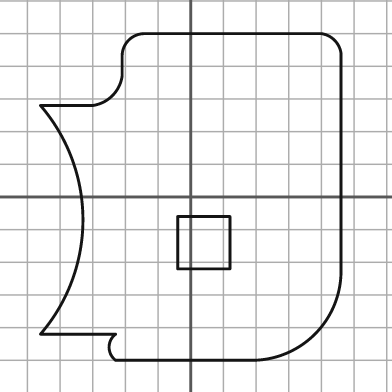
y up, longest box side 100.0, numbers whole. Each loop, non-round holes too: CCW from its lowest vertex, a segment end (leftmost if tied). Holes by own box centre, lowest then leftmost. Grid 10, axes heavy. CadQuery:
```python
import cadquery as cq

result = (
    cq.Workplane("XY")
    .moveTo(-23.0, -50.0)
    .lineTo(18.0, -50.0)
    .threePointArc((38.0, -42.0), (46.0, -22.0))
    .lineTo(46.0, 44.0)
    .threePointArc((44.0, 48.0), (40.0, 50.0))
    .lineTo(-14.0, 50.0)
    .threePointArc((-19.0, 48.0), (-21.0, 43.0))
    .lineTo(-21.0, 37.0)
    .threePointArc((-24.0, 31.0), (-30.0, 28.0))
    .lineTo(-46.0, 28.0)
    .threePointArc((-33.0, -7.0), (-46.0, -42.0))
    .lineTo(-23.0, -42.0)
    .threePointArc((-25.0, -46.0), (-23.0, -50.0))
    .close()
    .moveTo(-4.0, -22.0)
    .lineTo(12.0, -22.0)
    .lineTo(12.0, -6.0)
    .lineTo(-4.0, -6.0)
    .close()
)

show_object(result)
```